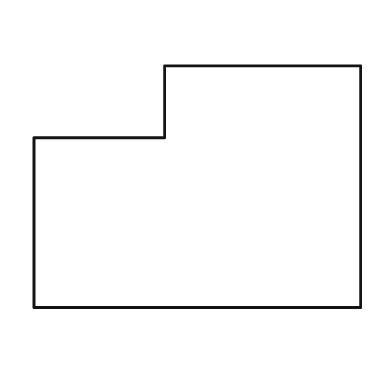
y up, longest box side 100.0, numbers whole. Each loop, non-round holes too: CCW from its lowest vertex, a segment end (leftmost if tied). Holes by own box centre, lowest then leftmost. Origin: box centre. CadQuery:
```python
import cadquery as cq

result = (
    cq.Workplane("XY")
    .moveTo(-50.0, -37.0)
    .lineTo(50.0, -37.0)
    .lineTo(50.0, 37.0)
    .lineTo(-10.0, 37.0)
    .lineTo(-10.0, 15.0)
    .lineTo(-50.0, 15.0)
    .close()
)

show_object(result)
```